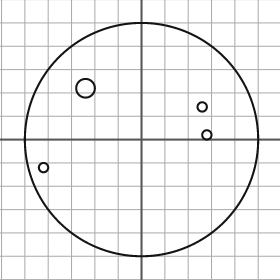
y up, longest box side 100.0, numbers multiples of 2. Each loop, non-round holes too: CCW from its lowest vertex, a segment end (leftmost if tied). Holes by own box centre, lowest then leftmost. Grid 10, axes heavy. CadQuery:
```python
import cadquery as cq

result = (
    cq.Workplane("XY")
    .moveTo(0.0, 0.0)
    .circle(50.0)
    .moveTo(-42.0, -12.0)
    .circle(2.0)
    .moveTo(28.0, 2.0)
    .circle(2.0)
    .moveTo(26.0, 14.0)
    .circle(2.0)
    .moveTo(-24.0, 22.0)
    .circle(4.0)
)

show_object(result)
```